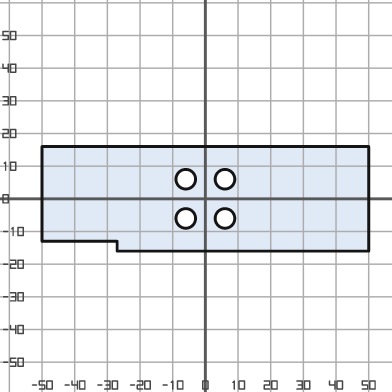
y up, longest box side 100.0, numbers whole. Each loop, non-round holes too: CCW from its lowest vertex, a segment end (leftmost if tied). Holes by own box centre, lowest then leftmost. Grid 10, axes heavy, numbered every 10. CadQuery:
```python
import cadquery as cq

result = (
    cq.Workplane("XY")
    .moveTo(-27.0, -16.0)
    .lineTo(50.0, -16.0)
    .lineTo(50.0, 16.0)
    .lineTo(-50.0, 16.0)
    .lineTo(-50.0, -13.0)
    .lineTo(-27.0, -13.0)
    .close()
    .moveTo(-6.0, -6.0)
    .circle(3.0)
    .moveTo(6.0, -6.0)
    .circle(3.0)
    .moveTo(-6.0, 6.0)
    .circle(3.0)
    .moveTo(6.0, 6.0)
    .circle(3.0)
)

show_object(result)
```